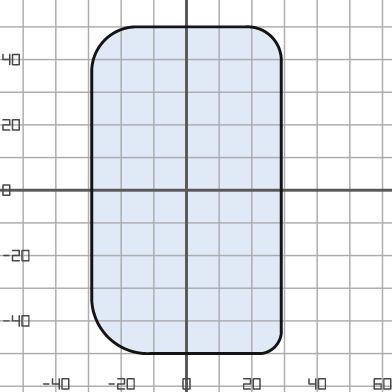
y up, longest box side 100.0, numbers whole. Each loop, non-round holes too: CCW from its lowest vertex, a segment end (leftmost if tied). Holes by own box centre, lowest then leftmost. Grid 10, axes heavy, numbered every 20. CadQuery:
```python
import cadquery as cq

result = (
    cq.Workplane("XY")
    .moveTo(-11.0, -50.0)
    .lineTo(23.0, -50.0)
    .threePointArc((27.0, -48.0), (29.0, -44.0))
    .lineTo(29.0, 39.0)
    .threePointArc((26.0, 47.0), (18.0, 50.0))
    .lineTo(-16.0, 50.0)
    .threePointArc((-25.0, 46.0), (-29.0, 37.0))
    .lineTo(-29.0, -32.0)
    .threePointArc((-24.0, -45.0), (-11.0, -50.0))
    .close()
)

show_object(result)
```